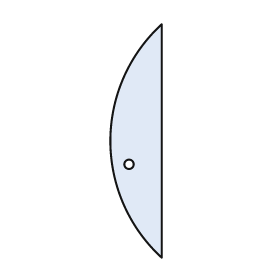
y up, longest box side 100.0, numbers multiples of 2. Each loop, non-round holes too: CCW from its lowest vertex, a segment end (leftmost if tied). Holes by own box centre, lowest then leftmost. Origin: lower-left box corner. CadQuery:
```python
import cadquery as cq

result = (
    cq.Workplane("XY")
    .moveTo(22.0, 0.0)
    .lineTo(22.0, 100.0)
    .threePointArc((0.0, 50.0), (22.0, 0.0))
    .close()
    .moveTo(8.0, 40.0)
    .circle(2.0)
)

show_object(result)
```